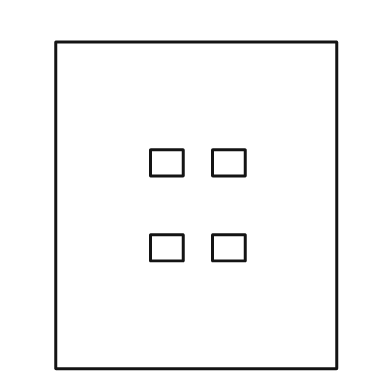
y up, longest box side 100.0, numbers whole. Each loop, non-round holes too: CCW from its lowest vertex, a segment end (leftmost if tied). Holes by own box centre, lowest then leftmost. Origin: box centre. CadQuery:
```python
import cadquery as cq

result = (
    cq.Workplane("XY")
    .moveTo(-43.0, -50.0)
    .lineTo(43.0, -50.0)
    .lineTo(43.0, 50.0)
    .lineTo(-43.0, 50.0)
    .close()
    .moveTo(-14.0, -17.0)
    .lineTo(-4.0, -17.0)
    .lineTo(-4.0, -9.0)
    .lineTo(-14.0, -9.0)
    .close()
    .moveTo(5.0, -17.0)
    .lineTo(15.0, -17.0)
    .lineTo(15.0, -9.0)
    .lineTo(5.0, -9.0)
    .close()
    .moveTo(-14.0, 9.0)
    .lineTo(-4.0, 9.0)
    .lineTo(-4.0, 17.0)
    .lineTo(-14.0, 17.0)
    .close()
    .moveTo(5.0, 9.0)
    .lineTo(15.0, 9.0)
    .lineTo(15.0, 17.0)
    .lineTo(5.0, 17.0)
    .close()
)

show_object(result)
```